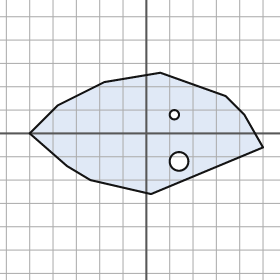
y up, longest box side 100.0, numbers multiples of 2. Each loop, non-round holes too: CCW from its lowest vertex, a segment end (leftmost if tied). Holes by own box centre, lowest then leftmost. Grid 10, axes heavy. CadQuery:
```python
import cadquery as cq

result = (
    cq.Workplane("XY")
    .moveTo(2.0, -26.0)
    .lineTo(50.0, -6.0)
    .lineTo(42.0, 8.0)
    .lineTo(34.0, 16.0)
    .lineTo(6.0, 26.0)
    .lineTo(-18.0, 22.0)
    .lineTo(-38.0, 12.0)
    .lineTo(-50.0, 0.0)
    .lineTo(-34.0, -14.0)
    .lineTo(-24.0, -20.0)
    .close()
    .moveTo(14.0, -12.0)
    .circle(4.0)
    .moveTo(12.0, 8.0)
    .circle(2.0)
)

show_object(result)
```